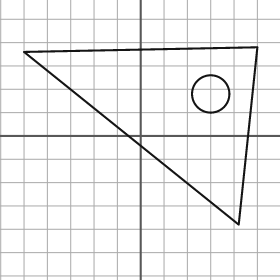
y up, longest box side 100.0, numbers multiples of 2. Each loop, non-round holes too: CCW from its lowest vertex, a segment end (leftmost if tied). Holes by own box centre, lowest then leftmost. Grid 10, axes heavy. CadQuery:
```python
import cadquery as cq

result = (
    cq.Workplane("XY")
    .moveTo(42.0, -38.0)
    .lineTo(50.0, 38.0)
    .lineTo(-50.0, 36.0)
    .close()
    .moveTo(30.0, 18.0)
    .circle(8.0)
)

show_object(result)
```